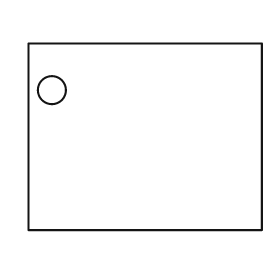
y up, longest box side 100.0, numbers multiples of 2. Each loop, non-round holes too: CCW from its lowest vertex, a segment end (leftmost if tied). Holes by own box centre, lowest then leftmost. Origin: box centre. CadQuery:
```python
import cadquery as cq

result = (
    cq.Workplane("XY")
    .moveTo(-50.0, -40.0)
    .lineTo(50.0, -40.0)
    .lineTo(50.0, 40.0)
    .lineTo(-50.0, 40.0)
    .close()
    .moveTo(-40.0, 20.0)
    .circle(6.0)
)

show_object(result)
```